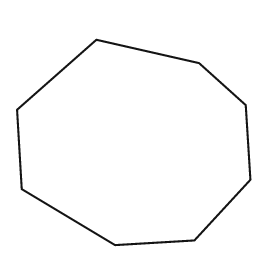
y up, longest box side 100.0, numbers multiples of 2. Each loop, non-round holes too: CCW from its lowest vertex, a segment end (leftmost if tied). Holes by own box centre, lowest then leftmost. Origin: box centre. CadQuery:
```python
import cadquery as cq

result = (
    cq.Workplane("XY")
    .moveTo(-8.0, -44.0)
    .lineTo(26.0, -42.0)
    .lineTo(50.0, -16.0)
    .lineTo(48.0, 16.0)
    .lineTo(28.0, 34.0)
    .lineTo(-16.0, 44.0)
    .lineTo(-50.0, 14.0)
    .lineTo(-48.0, -20.0)
    .close()
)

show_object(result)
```